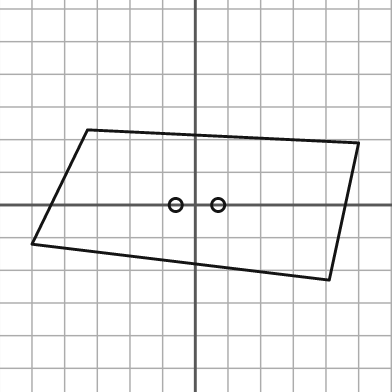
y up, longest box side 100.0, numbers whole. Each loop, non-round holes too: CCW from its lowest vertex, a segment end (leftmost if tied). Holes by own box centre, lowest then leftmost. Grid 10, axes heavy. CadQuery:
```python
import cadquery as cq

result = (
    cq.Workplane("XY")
    .moveTo(41.0, -23.0)
    .lineTo(50.0, 19.0)
    .lineTo(-33.0, 23.0)
    .lineTo(-50.0, -12.0)
    .close()
    .moveTo(-6.0, 0.0)
    .circle(2.0)
    .moveTo(7.0, 0.0)
    .circle(2.0)
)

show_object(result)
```